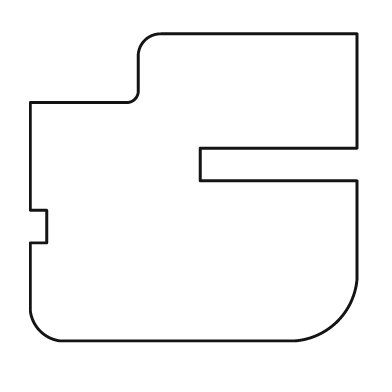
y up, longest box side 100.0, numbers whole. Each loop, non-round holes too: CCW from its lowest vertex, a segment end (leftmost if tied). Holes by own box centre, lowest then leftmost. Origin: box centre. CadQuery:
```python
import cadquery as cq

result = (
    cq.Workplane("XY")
    .moveTo(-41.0, -47.0)
    .lineTo(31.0, -47.0)
    .threePointArc((44.0, -41.0), (50.0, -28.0))
    .lineTo(50.0, 2.0)
    .lineTo(2.0, 2.0)
    .lineTo(2.0, 12.0)
    .lineTo(50.0, 12.0)
    .lineTo(50.0, 47.0)
    .lineTo(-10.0, 47.0)
    .threePointArc((-15.0, 45.0), (-17.0, 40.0))
    .lineTo(-17.0, 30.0)
    .threePointArc((-18.0, 27.0), (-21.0, 26.0))
    .lineTo(-50.0, 26.0)
    .lineTo(-50.0, -7.0)
    .lineTo(-45.0, -7.0)
    .lineTo(-45.0, -17.0)
    .lineTo(-50.0, -17.0)
    .lineTo(-50.0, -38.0)
    .threePointArc((-47.0, -44.0), (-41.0, -47.0))
    .close()
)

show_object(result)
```